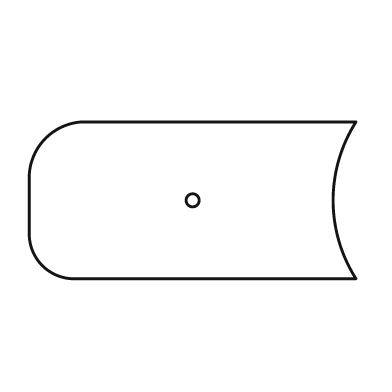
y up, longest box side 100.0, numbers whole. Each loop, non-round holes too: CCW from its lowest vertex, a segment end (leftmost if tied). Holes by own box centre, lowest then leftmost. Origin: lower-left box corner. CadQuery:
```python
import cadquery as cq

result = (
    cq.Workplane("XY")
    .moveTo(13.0, 0.0)
    .lineTo(100.0, 0.0)
    .threePointArc((93.0, 24.0), (100.0, 48.0))
    .lineTo(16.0, 48.0)
    .threePointArc((5.0, 43.0), (0.0, 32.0))
    .lineTo(0.0, 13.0)
    .threePointArc((4.0, 4.0), (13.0, 0.0))
    .close()
    .moveTo(50.0, 24.0)
    .circle(2.0)
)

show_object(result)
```